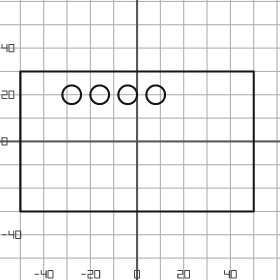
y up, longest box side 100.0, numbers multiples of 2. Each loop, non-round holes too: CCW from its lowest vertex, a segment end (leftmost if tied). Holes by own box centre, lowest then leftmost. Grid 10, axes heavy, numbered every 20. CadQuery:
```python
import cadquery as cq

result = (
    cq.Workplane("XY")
    .moveTo(-50.0, -30.0)
    .lineTo(50.0, -30.0)
    .lineTo(50.0, 30.0)
    .lineTo(-50.0, 30.0)
    .close()
    .moveTo(-28.0, 20.0)
    .circle(4.0)
    .moveTo(-16.0, 20.0)
    .circle(4.0)
    .moveTo(-4.0, 20.0)
    .circle(4.0)
    .moveTo(8.0, 20.0)
    .circle(4.0)
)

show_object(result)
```